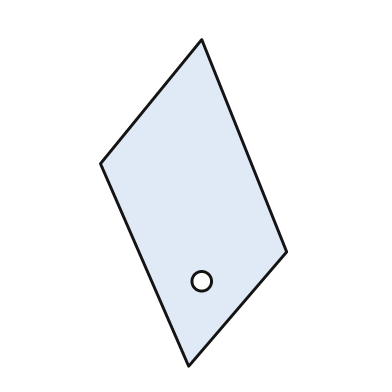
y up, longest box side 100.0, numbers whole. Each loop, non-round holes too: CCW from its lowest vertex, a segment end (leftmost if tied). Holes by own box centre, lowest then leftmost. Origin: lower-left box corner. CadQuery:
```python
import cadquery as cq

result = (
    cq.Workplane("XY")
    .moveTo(27.0, 0.0)
    .lineTo(57.0, 35.0)
    .lineTo(31.0, 100.0)
    .lineTo(0.0, 62.0)
    .close()
    .moveTo(31.0, 26.0)
    .circle(3.0)
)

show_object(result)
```